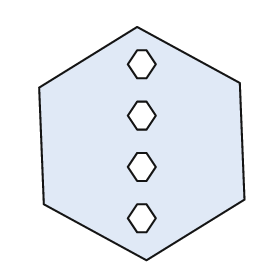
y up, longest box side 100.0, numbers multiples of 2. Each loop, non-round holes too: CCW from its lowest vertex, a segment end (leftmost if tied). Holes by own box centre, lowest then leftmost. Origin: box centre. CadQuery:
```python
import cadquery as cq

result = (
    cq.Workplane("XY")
    .moveTo(2.0, -50.0)
    .lineTo(44.0, -24.0)
    .lineTo(42.0, 26.0)
    .lineTo(-2.0, 50.0)
    .lineTo(-44.0, 24.0)
    .lineTo(-42.0, -26.0)
    .close()
    .moveTo(-2.0, -38.0)
    .lineTo(2.0, -38.0)
    .lineTo(6.0, -32.0)
    .lineTo(2.0, -26.0)
    .lineTo(-2.0, -26.0)
    .lineTo(-6.0, -32.0)
    .close()
    .moveTo(-2.0, -16.0)
    .lineTo(2.0, -16.0)
    .lineTo(6.0, -10.0)
    .lineTo(2.0, -4.0)
    .lineTo(-2.0, -4.0)
    .lineTo(-6.0, -10.0)
    .close()
    .moveTo(-2.0, 6.0)
    .lineTo(2.0, 6.0)
    .lineTo(6.0, 12.0)
    .lineTo(2.0, 18.0)
    .lineTo(-2.0, 18.0)
    .lineTo(-6.0, 12.0)
    .close()
    .moveTo(-2.0, 28.0)
    .lineTo(2.0, 28.0)
    .lineTo(6.0, 34.0)
    .lineTo(2.0, 40.0)
    .lineTo(-2.0, 40.0)
    .lineTo(-6.0, 34.0)
    .close()
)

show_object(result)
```